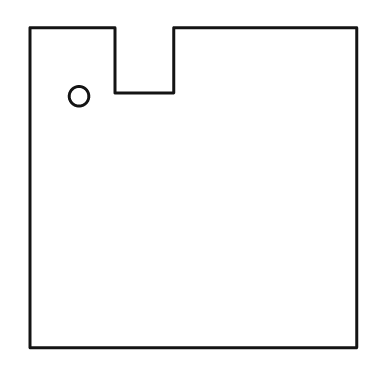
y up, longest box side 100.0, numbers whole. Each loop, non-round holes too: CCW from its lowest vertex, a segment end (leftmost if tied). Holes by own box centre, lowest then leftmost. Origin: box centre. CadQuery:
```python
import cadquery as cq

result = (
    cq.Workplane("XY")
    .moveTo(-50.0, -49.0)
    .lineTo(50.0, -49.0)
    .lineTo(50.0, 49.0)
    .lineTo(-6.0, 49.0)
    .lineTo(-6.0, 29.0)
    .lineTo(-24.0, 29.0)
    .lineTo(-24.0, 49.0)
    .lineTo(-50.0, 49.0)
    .close()
    .moveTo(-35.0, 28.0)
    .circle(3.0)
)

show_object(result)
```